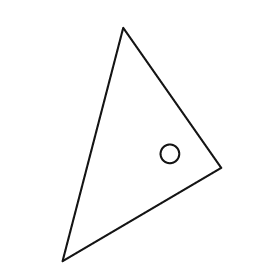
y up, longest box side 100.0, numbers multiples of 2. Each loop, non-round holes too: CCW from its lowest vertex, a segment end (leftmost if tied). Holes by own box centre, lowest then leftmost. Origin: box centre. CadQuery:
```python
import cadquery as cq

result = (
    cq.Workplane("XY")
    .moveTo(-34.0, -50.0)
    .lineTo(34.0, -10.0)
    .lineTo(-8.0, 50.0)
    .close()
    .moveTo(12.0, -4.0)
    .circle(4.0)
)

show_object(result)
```